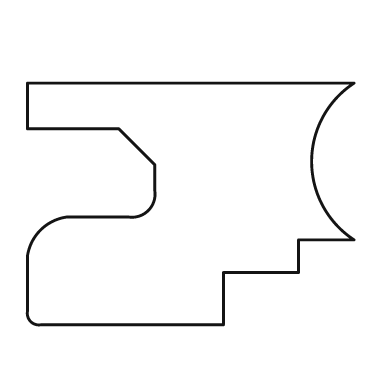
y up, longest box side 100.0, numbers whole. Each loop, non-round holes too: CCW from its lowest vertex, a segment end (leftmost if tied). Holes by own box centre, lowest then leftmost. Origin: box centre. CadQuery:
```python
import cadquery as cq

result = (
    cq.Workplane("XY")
    .moveTo(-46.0, -37.0)
    .lineTo(10.0, -37.0)
    .lineTo(10.0, -21.0)
    .lineTo(33.0, -21.0)
    .lineTo(33.0, -11.0)
    .lineTo(50.0, -11.0)
    .threePointArc((37.0, 13.0), (50.0, 37.0))
    .lineTo(-50.0, 37.0)
    .lineTo(-50.0, 23.0)
    .lineTo(-22.0, 23.0)
    .lineTo(-11.0, 12.0)
    .lineTo(-11.0, 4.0)
    .threePointArc((-13.0, -2.0), (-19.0, -4.0))
    .lineTo(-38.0, -4.0)
    .threePointArc((-46.0, -8.0), (-50.0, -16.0))
    .lineTo(-50.0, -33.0)
    .threePointArc((-49.0, -36.0), (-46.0, -37.0))
    .close()
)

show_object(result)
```